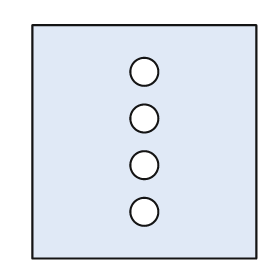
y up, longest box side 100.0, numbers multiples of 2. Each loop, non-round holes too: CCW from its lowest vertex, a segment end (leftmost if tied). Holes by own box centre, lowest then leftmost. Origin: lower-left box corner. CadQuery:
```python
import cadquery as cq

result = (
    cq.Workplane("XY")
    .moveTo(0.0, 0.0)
    .lineTo(96.0, 0.0)
    .lineTo(96.0, 100.0)
    .lineTo(0.0, 100.0)
    .close()
    .moveTo(48.0, 20.0)
    .circle(6.0)
    .moveTo(48.0, 40.0)
    .circle(6.0)
    .moveTo(48.0, 60.0)
    .circle(6.0)
    .moveTo(48.0, 80.0)
    .circle(6.0)
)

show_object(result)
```